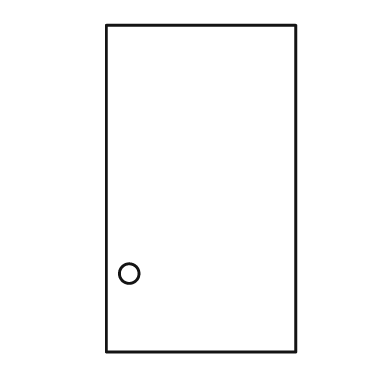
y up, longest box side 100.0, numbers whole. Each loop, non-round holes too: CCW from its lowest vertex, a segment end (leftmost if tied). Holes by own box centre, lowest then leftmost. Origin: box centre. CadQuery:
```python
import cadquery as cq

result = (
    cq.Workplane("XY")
    .moveTo(-29.0, -50.0)
    .lineTo(29.0, -50.0)
    .lineTo(29.0, 50.0)
    .lineTo(-29.0, 50.0)
    .close()
    .moveTo(-22.0, -26.0)
    .circle(3.0)
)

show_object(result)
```